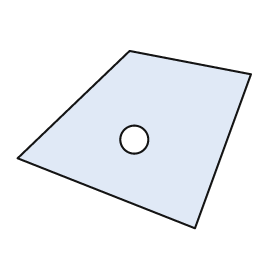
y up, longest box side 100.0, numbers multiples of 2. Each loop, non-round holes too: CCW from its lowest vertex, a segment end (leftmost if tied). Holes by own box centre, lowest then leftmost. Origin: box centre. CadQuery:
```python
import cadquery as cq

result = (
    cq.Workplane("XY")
    .moveTo(26.0, -38.0)
    .lineTo(50.0, 28.0)
    .lineTo(-2.0, 38.0)
    .lineTo(-50.0, -8.0)
    .close()
    .moveTo(0.0, 0.0)
    .circle(6.0)
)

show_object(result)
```